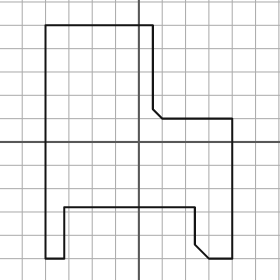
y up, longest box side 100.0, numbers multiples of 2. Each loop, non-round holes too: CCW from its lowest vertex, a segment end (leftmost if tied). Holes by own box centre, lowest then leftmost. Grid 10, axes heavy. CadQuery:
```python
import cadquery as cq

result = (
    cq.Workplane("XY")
    .moveTo(-40.0, -50.0)
    .lineTo(-32.0, -50.0)
    .lineTo(-32.0, -28.0)
    .lineTo(24.0, -28.0)
    .lineTo(24.0, -44.0)
    .lineTo(30.0, -50.0)
    .lineTo(40.0, -50.0)
    .lineTo(40.0, 10.0)
    .lineTo(10.0, 10.0)
    .lineTo(6.0, 14.0)
    .lineTo(6.0, 50.0)
    .lineTo(-40.0, 50.0)
    .close()
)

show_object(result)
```